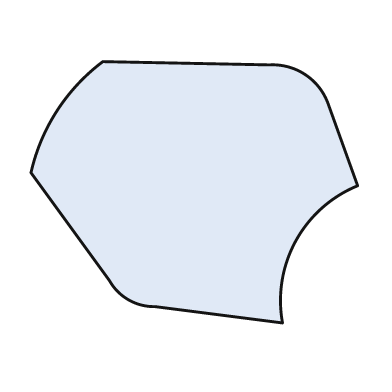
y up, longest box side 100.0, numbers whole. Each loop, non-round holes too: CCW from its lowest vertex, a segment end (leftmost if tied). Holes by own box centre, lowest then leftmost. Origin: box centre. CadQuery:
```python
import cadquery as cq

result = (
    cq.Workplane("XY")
    .moveTo(27.0, -40.0)
    .threePointArc((31.0, -15.0), (50.0, 2.0))
    .lineTo(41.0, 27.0)
    .threePointArc((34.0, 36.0), (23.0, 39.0))
    .lineTo(-28.0, 40.0)
    .threePointArc((-42.0, 25.0), (-50.0, 6.0))
    .lineTo(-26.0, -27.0)
    .threePointArc((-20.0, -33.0), (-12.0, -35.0))
    .close()
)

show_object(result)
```